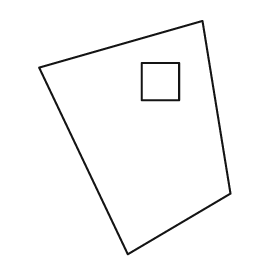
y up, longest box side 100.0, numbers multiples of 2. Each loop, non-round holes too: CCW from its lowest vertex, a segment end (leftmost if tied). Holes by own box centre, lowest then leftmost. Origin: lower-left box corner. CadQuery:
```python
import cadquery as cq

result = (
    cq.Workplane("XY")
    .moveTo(38.0, 0.0)
    .lineTo(82.0, 26.0)
    .lineTo(70.0, 100.0)
    .lineTo(0.0, 80.0)
    .close()
    .moveTo(44.0, 66.0)
    .lineTo(60.0, 66.0)
    .lineTo(60.0, 82.0)
    .lineTo(44.0, 82.0)
    .close()
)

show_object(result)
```